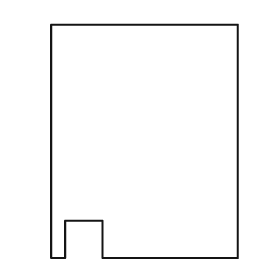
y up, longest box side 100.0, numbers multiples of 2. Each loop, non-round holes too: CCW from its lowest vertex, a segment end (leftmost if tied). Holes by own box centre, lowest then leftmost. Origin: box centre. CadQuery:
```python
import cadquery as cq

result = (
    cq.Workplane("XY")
    .moveTo(-40.0, -50.0)
    .lineTo(-34.0, -50.0)
    .lineTo(-34.0, -34.0)
    .lineTo(-18.0, -34.0)
    .lineTo(-18.0, -50.0)
    .lineTo(40.0, -50.0)
    .lineTo(40.0, 50.0)
    .lineTo(-40.0, 50.0)
    .close()
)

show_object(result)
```